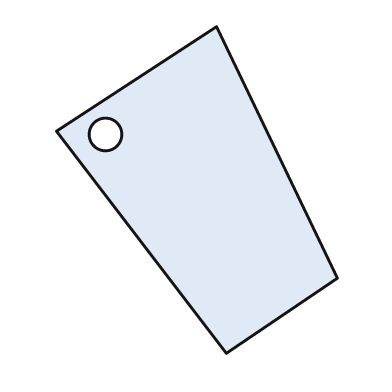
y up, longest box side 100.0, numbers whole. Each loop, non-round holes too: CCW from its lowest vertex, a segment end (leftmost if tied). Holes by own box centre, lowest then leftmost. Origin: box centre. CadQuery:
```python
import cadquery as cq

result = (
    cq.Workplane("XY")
    .moveTo(9.0, -50.0)
    .lineTo(43.0, -27.0)
    .lineTo(6.0, 50.0)
    .lineTo(-43.0, 18.0)
    .close()
    .moveTo(-28.0, 17.0)
    .circle(5.0)
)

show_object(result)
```